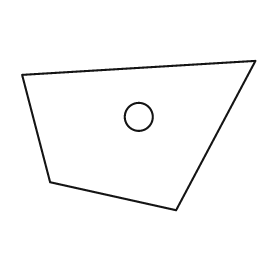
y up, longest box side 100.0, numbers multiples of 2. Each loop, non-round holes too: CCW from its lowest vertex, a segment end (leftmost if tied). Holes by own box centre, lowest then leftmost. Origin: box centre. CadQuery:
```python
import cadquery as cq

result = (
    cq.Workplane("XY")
    .moveTo(16.0, -32.0)
    .lineTo(50.0, 32.0)
    .lineTo(-50.0, 26.0)
    .lineTo(-38.0, -20.0)
    .close()
    .moveTo(0.0, 8.0)
    .circle(6.0)
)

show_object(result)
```